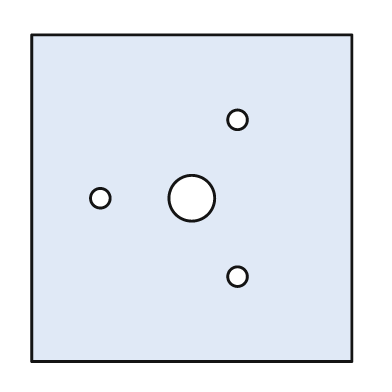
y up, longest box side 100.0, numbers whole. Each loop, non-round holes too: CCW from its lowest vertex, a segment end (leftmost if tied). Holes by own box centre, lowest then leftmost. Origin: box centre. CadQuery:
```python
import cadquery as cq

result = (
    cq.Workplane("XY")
    .moveTo(-49.0, -50.0)
    .lineTo(49.0, -50.0)
    .lineTo(49.0, 50.0)
    .lineTo(-49.0, 50.0)
    .close()
    .moveTo(14.0, -24.0)
    .circle(3.0)
    .moveTo(-28.0, 0.0)
    .circle(3.0)
    .moveTo(0.0, 0.0)
    .circle(7.0)
    .moveTo(14.0, 24.0)
    .circle(3.0)
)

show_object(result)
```